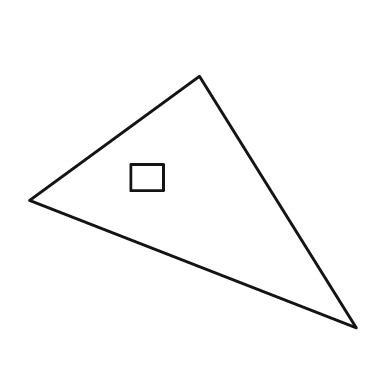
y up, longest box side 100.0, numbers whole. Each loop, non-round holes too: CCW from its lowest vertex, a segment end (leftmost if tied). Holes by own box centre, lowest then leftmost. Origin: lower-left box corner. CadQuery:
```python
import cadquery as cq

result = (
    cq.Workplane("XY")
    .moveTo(100.0, 0.0)
    .lineTo(52.0, 77.0)
    .lineTo(0.0, 39.0)
    .close()
    .moveTo(31.0, 42.0)
    .lineTo(41.0, 42.0)
    .lineTo(41.0, 50.0)
    .lineTo(31.0, 50.0)
    .close()
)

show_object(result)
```